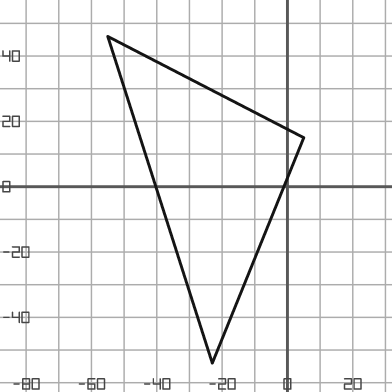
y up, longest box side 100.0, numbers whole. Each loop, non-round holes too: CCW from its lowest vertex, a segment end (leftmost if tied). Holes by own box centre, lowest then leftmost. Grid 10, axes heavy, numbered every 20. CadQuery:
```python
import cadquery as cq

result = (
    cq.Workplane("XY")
    .moveTo(-23.0, -54.0)
    .lineTo(5.0, 15.0)
    .lineTo(-55.0, 46.0)
    .close()
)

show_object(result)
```